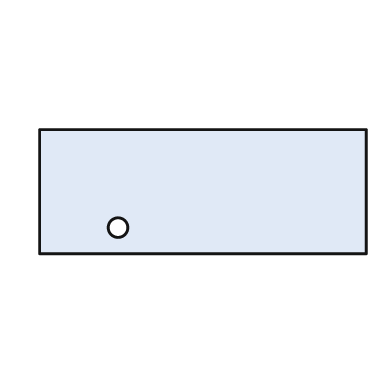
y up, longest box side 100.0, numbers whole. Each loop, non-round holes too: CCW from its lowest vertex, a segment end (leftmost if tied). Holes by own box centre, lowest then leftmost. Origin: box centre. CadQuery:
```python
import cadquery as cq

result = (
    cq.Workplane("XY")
    .moveTo(-50.0, -19.0)
    .lineTo(50.0, -19.0)
    .lineTo(50.0, 19.0)
    .lineTo(-50.0, 19.0)
    .close()
    .moveTo(-26.0, -11.0)
    .circle(3.0)
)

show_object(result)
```